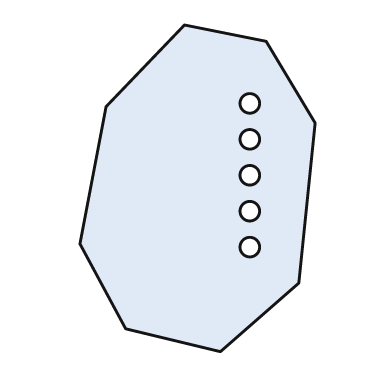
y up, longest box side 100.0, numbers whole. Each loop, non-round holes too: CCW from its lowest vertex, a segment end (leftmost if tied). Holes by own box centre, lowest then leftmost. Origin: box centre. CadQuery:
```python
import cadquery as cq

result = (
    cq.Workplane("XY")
    .moveTo(7.0, -50.0)
    .lineTo(31.0, -29.0)
    .lineTo(36.0, 20.0)
    .lineTo(21.0, 45.0)
    .lineTo(-4.0, 50.0)
    .lineTo(-28.0, 25.0)
    .lineTo(-36.0, -17.0)
    .lineTo(-22.0, -43.0)
    .close()
    .moveTo(16.0, -18.0)
    .circle(3.0)
    .moveTo(16.0, -7.0)
    .circle(3.0)
    .moveTo(16.0, 4.0)
    .circle(3.0)
    .moveTo(16.0, 15.0)
    .circle(3.0)
    .moveTo(16.0, 26.0)
    .circle(3.0)
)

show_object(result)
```